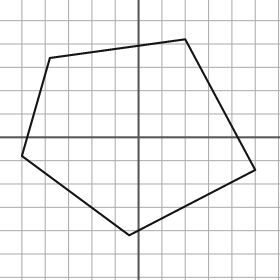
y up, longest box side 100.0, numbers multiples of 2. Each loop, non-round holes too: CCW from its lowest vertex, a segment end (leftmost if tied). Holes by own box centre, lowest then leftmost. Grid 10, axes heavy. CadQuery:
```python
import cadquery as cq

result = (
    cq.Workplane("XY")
    .moveTo(-4.0, -42.0)
    .lineTo(50.0, -14.0)
    .lineTo(20.0, 42.0)
    .lineTo(-38.0, 34.0)
    .lineTo(-50.0, -8.0)
    .close()
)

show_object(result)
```